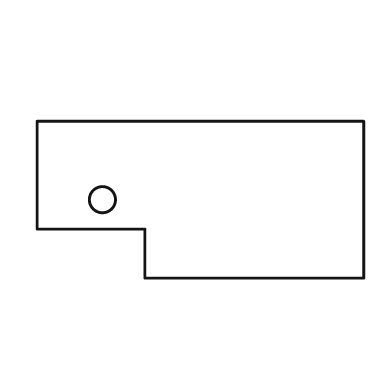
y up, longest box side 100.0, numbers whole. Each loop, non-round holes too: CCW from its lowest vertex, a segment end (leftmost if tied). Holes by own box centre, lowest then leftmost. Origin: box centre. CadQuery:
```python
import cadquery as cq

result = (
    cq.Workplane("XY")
    .moveTo(-17.0, -24.0)
    .lineTo(50.0, -24.0)
    .lineTo(50.0, 24.0)
    .lineTo(-50.0, 24.0)
    .lineTo(-50.0, -9.0)
    .lineTo(-17.0, -9.0)
    .close()
    .moveTo(-30.0, 0.0)
    .circle(4.0)
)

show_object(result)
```